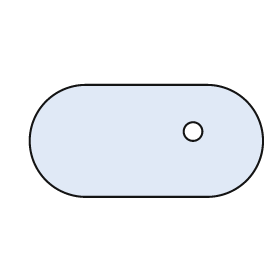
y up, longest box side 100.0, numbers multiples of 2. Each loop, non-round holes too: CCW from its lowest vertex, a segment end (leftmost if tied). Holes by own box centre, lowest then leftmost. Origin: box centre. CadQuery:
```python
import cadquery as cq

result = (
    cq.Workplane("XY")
    .moveTo(-26.0, -24.0)
    .lineTo(26.0, -24.0)
    .threePointArc((50.0, 0.0), (26.0, 24.0))
    .lineTo(-26.0, 24.0)
    .threePointArc((-50.0, 0.0), (-26.0, -24.0))
    .close()
    .moveTo(20.0, 4.0)
    .circle(4.0)
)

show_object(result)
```